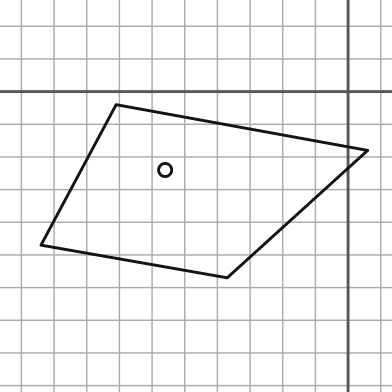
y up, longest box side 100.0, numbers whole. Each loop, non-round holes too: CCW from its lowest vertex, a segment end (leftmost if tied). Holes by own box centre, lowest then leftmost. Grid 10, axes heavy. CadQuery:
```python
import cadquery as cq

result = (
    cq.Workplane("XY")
    .moveTo(-37.0, -57.0)
    .lineTo(6.0, -18.0)
    .lineTo(-71.0, -4.0)
    .lineTo(-94.0, -47.0)
    .close()
    .moveTo(-56.0, -24.0)
    .circle(2.0)
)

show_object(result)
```